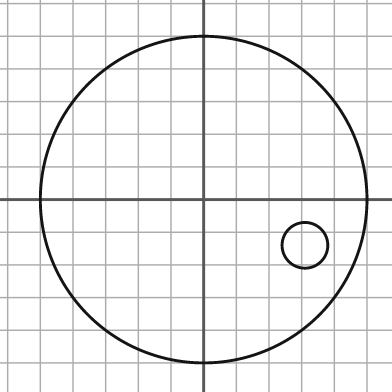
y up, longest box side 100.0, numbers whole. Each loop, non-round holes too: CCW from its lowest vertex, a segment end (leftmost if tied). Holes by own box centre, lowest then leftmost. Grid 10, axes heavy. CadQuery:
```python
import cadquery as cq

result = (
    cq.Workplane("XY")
    .moveTo(0.0, 0.0)
    .circle(50.0)
    .moveTo(31.0, -14.0)
    .circle(7.0)
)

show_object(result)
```